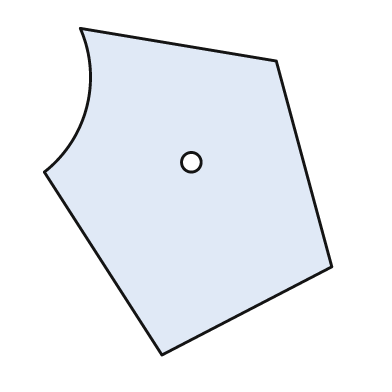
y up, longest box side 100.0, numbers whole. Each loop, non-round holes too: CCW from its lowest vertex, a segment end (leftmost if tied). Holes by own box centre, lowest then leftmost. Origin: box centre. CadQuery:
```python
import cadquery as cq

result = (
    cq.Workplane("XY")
    .moveTo(-8.0, -50.0)
    .lineTo(44.0, -23.0)
    .lineTo(27.0, 40.0)
    .lineTo(-33.0, 50.0)
    .threePointArc((-31.0, 26.0), (-44.0, 6.0))
    .close()
    .moveTo(1.0, 9.0)
    .circle(3.0)
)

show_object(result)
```